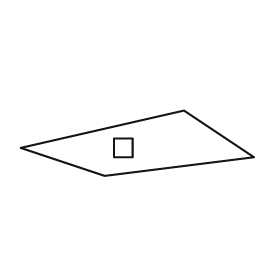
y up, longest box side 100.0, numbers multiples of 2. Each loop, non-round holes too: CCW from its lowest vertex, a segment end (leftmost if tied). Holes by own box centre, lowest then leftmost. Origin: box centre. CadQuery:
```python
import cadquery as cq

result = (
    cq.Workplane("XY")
    .moveTo(-14.0, -14.0)
    .lineTo(50.0, -6.0)
    .lineTo(20.0, 14.0)
    .lineTo(-50.0, -2.0)
    .close()
    .moveTo(-10.0, -6.0)
    .lineTo(-2.0, -6.0)
    .lineTo(-2.0, 2.0)
    .lineTo(-10.0, 2.0)
    .close()
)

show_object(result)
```